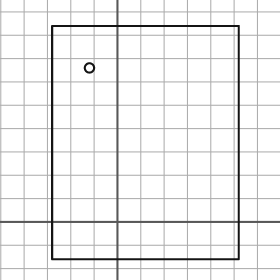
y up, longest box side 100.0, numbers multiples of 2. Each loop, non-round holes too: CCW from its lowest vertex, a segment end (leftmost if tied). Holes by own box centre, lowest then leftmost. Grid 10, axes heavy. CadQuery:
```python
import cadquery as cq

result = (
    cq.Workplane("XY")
    .moveTo(-28.0, -16.0)
    .lineTo(52.0, -16.0)
    .lineTo(52.0, 84.0)
    .lineTo(-28.0, 84.0)
    .close()
    .moveTo(-12.0, 66.0)
    .circle(2.0)
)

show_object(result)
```